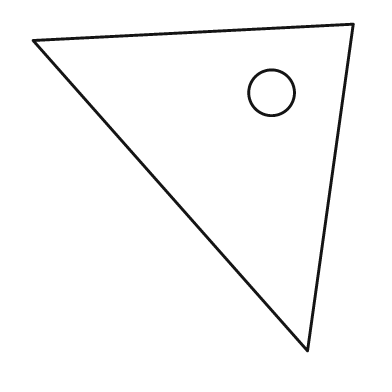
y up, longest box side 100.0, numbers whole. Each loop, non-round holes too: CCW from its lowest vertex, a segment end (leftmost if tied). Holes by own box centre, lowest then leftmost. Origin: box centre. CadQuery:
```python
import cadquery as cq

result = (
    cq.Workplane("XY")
    .moveTo(35.0, -50.0)
    .lineTo(49.0, 50.0)
    .lineTo(-49.0, 45.0)
    .close()
    .moveTo(24.0, 29.0)
    .circle(7.0)
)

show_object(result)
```